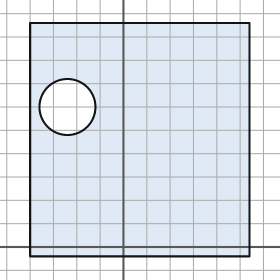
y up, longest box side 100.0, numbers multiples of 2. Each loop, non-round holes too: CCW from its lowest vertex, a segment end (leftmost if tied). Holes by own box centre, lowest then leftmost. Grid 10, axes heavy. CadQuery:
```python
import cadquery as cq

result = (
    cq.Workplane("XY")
    .moveTo(-40.0, -4.0)
    .lineTo(54.0, -4.0)
    .lineTo(54.0, 96.0)
    .lineTo(-40.0, 96.0)
    .close()
    .moveTo(-24.0, 60.0)
    .circle(12.0)
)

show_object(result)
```